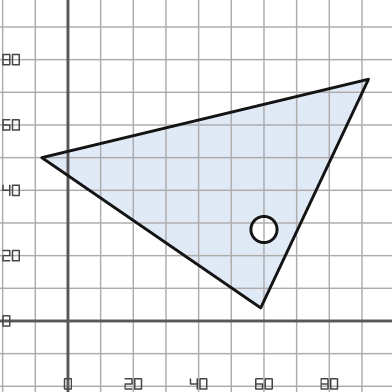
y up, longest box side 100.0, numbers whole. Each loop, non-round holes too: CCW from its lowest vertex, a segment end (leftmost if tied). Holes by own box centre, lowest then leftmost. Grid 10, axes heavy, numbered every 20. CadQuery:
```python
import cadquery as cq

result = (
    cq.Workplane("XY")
    .moveTo(59.0, 4.0)
    .lineTo(92.0, 74.0)
    .lineTo(-8.0, 50.0)
    .close()
    .moveTo(60.0, 28.0)
    .circle(4.0)
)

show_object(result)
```